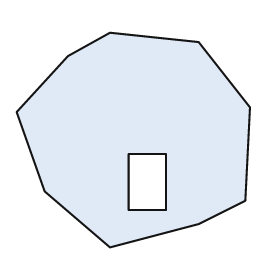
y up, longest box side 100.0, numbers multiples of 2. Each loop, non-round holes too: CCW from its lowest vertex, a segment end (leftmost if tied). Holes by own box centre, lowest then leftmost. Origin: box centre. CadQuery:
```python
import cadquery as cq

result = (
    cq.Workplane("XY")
    .moveTo(-10.0, -46.0)
    .lineTo(28.0, -36.0)
    .lineTo(48.0, -26.0)
    .lineTo(50.0, 14.0)
    .lineTo(28.0, 42.0)
    .lineTo(-10.0, 46.0)
    .lineTo(-28.0, 36.0)
    .lineTo(-50.0, 12.0)
    .lineTo(-38.0, -22.0)
    .close()
    .moveTo(-2.0, -30.0)
    .lineTo(14.0, -30.0)
    .lineTo(14.0, -6.0)
    .lineTo(-2.0, -6.0)
    .close()
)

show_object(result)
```